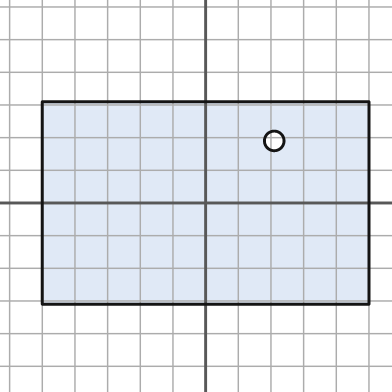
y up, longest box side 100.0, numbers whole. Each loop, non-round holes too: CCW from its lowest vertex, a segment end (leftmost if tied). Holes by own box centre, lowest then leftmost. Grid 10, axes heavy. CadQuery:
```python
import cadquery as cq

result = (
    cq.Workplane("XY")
    .moveTo(-50.0, -31.0)
    .lineTo(50.0, -31.0)
    .lineTo(50.0, 31.0)
    .lineTo(-50.0, 31.0)
    .close()
    .moveTo(21.0, 19.0)
    .circle(3.0)
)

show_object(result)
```